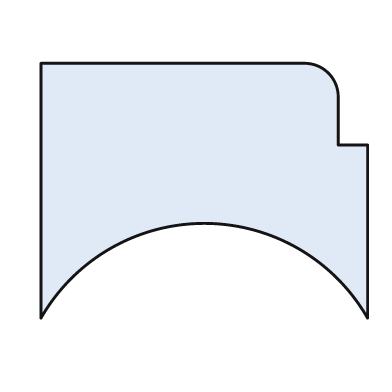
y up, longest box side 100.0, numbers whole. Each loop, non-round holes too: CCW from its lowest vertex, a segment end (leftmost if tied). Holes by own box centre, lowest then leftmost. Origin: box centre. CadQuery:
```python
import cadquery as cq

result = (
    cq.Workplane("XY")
    .moveTo(-50.0, -39.0)
    .threePointArc((0.0, -10.0), (50.0, -39.0))
    .lineTo(50.0, 14.0)
    .lineTo(41.0, 14.0)
    .lineTo(41.0, 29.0)
    .threePointArc((38.0, 36.0), (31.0, 39.0))
    .lineTo(-50.0, 39.0)
    .close()
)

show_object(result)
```